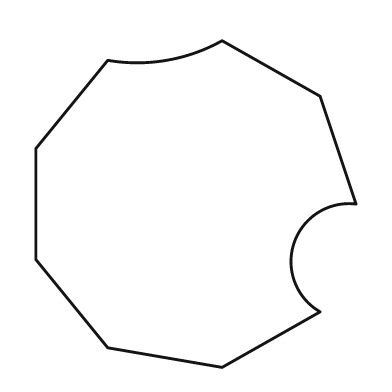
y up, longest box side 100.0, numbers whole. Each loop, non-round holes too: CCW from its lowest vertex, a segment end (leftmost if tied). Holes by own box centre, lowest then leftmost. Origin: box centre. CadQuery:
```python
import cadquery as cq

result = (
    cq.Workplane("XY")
    .moveTo(8.0, -50.0)
    .lineTo(38.0, -33.0)
    .threePointArc((30.0, -12.0), (49.0, 0.0))
    .lineTo(38.0, 33.0)
    .lineTo(8.0, 50.0)
    .threePointArc((-9.0, 44.0), (-27.0, 44.0))
    .lineTo(-49.0, 17.0)
    .lineTo(-49.0, -17.0)
    .lineTo(-27.0, -44.0)
    .close()
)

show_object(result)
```